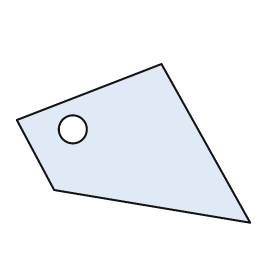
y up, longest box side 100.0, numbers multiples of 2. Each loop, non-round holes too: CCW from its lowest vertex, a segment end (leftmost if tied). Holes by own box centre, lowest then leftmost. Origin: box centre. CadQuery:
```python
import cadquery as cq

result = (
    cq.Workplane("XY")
    .moveTo(50.0, -34.0)
    .lineTo(12.0, 34.0)
    .lineTo(-50.0, 10.0)
    .lineTo(-34.0, -20.0)
    .close()
    .moveTo(-26.0, 6.0)
    .circle(6.0)
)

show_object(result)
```